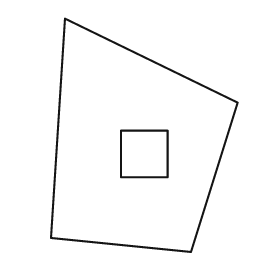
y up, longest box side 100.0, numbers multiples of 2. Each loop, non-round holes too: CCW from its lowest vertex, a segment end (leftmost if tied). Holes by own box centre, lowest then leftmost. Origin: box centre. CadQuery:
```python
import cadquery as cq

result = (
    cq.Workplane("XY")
    .moveTo(20.0, -50.0)
    .lineTo(40.0, 14.0)
    .lineTo(-34.0, 50.0)
    .lineTo(-40.0, -44.0)
    .close()
    .moveTo(-10.0, -18.0)
    .lineTo(10.0, -18.0)
    .lineTo(10.0, 2.0)
    .lineTo(-10.0, 2.0)
    .close()
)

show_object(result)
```